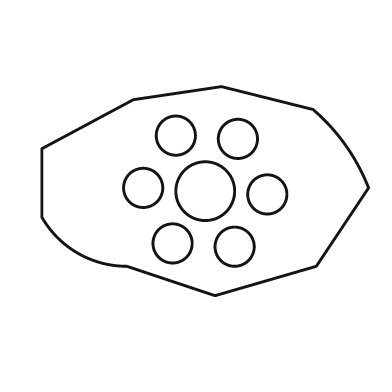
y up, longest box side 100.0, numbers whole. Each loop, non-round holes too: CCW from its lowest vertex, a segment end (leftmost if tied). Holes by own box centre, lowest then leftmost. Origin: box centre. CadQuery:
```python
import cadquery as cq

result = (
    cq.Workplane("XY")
    .moveTo(3.0, -32.0)
    .lineTo(34.0, -23.0)
    .lineTo(50.0, 1.0)
    .threePointArc((43.0, 14.0), (33.0, 25.0))
    .lineTo(5.0, 32.0)
    .lineTo(-22.0, 28.0)
    .lineTo(-50.0, 13.0)
    .lineTo(-50.0, -8.0)
    .threePointArc((-39.0, -19.0), (-24.0, -23.0))
    .close()
    .moveTo(9.0, -17.0)
    .circle(6.0)
    .moveTo(-10.0, -16.0)
    .circle(6.0)
    .moveTo(19.0, -1.0)
    .circle(6.0)
    .moveTo(0.0, 0.0)
    .circle(9.0)
    .moveTo(-19.0, 1.0)
    .circle(6.0)
    .moveTo(10.0, 16.0)
    .circle(6.0)
    .moveTo(-9.0, 17.0)
    .circle(6.0)
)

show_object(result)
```